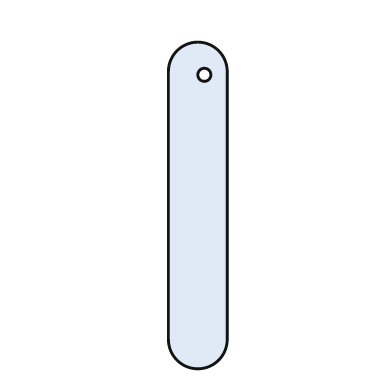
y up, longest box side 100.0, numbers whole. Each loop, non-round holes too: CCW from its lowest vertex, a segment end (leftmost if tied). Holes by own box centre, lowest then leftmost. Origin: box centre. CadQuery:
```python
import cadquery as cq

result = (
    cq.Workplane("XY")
    .moveTo(-9.0, -41.0)
    .threePointArc((0.0, -50.0), (9.0, -41.0))
    .lineTo(9.0, 41.0)
    .threePointArc((0.0, 50.0), (-9.0, 41.0))
    .close()
    .moveTo(2.0, 40.0)
    .circle(2.0)
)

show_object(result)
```